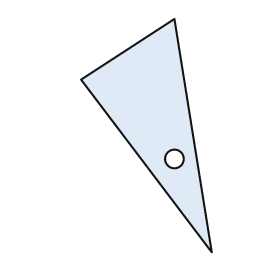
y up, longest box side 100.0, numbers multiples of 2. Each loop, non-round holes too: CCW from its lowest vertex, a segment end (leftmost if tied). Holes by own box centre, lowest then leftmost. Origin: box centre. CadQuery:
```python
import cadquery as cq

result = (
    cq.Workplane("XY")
    .moveTo(28.0, -50.0)
    .lineTo(12.0, 50.0)
    .lineTo(-28.0, 24.0)
    .close()
    .moveTo(12.0, -10.0)
    .circle(4.0)
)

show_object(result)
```